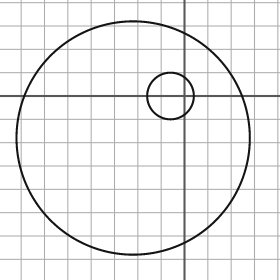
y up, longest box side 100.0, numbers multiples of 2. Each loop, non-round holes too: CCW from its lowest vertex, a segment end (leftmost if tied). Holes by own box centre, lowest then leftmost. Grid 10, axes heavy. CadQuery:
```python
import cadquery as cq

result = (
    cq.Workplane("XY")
    .moveTo(-22.0, -18.0)
    .circle(50.0)
    .moveTo(-6.0, 0.0)
    .circle(10.0)
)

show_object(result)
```